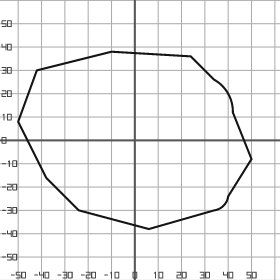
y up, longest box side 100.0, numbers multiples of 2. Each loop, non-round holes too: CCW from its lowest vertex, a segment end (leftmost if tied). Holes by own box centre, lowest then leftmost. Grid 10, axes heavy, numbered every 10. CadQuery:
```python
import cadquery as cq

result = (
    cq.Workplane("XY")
    .moveTo(6.0, -38.0)
    .lineTo(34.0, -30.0)
    .threePointArc((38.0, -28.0), (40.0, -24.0))
    .lineTo(50.0, -8.0)
    .lineTo(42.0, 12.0)
    .threePointArc((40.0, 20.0), (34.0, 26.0))
    .lineTo(24.0, 36.0)
    .lineTo(-10.0, 38.0)
    .lineTo(-42.0, 30.0)
    .lineTo(-50.0, 8.0)
    .lineTo(-38.0, -16.0)
    .lineTo(-24.0, -30.0)
    .close()
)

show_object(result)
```